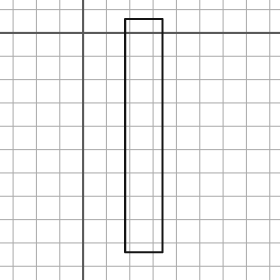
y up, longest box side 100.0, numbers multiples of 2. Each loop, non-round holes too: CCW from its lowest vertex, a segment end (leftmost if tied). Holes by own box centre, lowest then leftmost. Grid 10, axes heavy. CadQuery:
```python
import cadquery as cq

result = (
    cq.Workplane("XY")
    .moveTo(18.0, -94.0)
    .lineTo(34.0, -94.0)
    .lineTo(34.0, 6.0)
    .lineTo(18.0, 6.0)
    .close()
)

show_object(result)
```